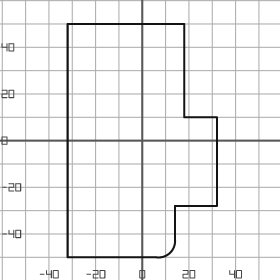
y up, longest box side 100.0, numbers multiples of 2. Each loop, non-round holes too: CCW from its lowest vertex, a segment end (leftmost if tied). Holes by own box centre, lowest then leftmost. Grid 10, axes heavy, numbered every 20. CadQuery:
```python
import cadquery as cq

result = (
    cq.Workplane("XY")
    .moveTo(-32.0, -50.0)
    .lineTo(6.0, -50.0)
    .threePointArc((12.0, -48.0), (14.0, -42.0))
    .lineTo(14.0, -28.0)
    .lineTo(32.0, -28.0)
    .lineTo(32.0, 10.0)
    .lineTo(18.0, 10.0)
    .lineTo(18.0, 50.0)
    .lineTo(-32.0, 50.0)
    .close()
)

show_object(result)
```